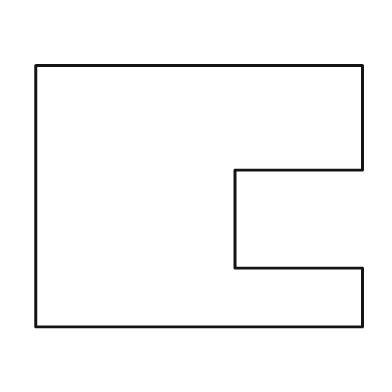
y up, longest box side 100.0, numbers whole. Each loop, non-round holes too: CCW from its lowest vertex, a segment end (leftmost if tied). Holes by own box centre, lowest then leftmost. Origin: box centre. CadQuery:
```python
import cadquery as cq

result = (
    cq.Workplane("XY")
    .moveTo(-50.0, -40.0)
    .lineTo(50.0, -40.0)
    .lineTo(50.0, -22.0)
    .lineTo(11.0, -22.0)
    .lineTo(11.0, 8.0)
    .lineTo(50.0, 8.0)
    .lineTo(50.0, 40.0)
    .lineTo(-50.0, 40.0)
    .close()
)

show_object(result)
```